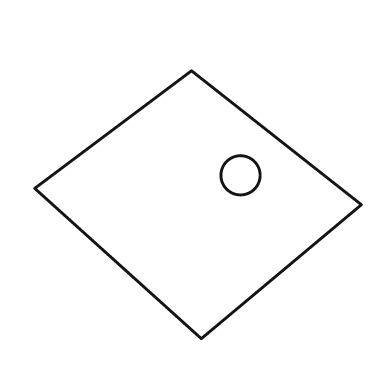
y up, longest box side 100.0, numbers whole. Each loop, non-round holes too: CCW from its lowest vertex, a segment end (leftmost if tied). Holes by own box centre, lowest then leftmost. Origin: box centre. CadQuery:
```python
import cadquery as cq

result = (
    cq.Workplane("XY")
    .moveTo(1.0, -41.0)
    .lineTo(50.0, 0.0)
    .lineTo(-2.0, 41.0)
    .lineTo(-50.0, 5.0)
    .close()
    .moveTo(13.0, 9.0)
    .circle(6.0)
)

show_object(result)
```